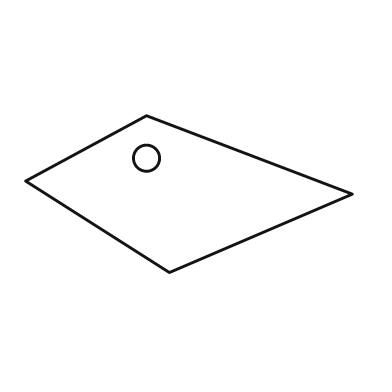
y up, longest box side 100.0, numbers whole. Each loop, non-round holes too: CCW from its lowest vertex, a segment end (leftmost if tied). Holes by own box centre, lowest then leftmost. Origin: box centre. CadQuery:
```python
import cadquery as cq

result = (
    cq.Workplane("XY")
    .moveTo(-6.0, -24.0)
    .lineTo(50.0, 0.0)
    .lineTo(-13.0, 24.0)
    .lineTo(-50.0, 4.0)
    .close()
    .moveTo(-13.0, 11.0)
    .circle(4.0)
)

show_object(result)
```